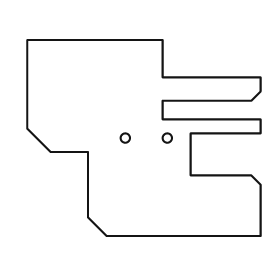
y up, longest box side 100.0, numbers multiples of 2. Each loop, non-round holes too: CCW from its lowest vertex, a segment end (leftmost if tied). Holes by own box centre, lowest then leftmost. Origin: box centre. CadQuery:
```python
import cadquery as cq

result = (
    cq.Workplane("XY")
    .moveTo(-16.0, -42.0)
    .lineTo(50.0, -42.0)
    .lineTo(50.0, -20.0)
    .lineTo(46.0, -16.0)
    .lineTo(20.0, -16.0)
    .lineTo(20.0, 2.0)
    .lineTo(50.0, 2.0)
    .lineTo(50.0, 8.0)
    .lineTo(8.0, 8.0)
    .lineTo(8.0, 16.0)
    .lineTo(46.0, 16.0)
    .lineTo(50.0, 20.0)
    .lineTo(50.0, 26.0)
    .lineTo(8.0, 26.0)
    .lineTo(8.0, 42.0)
    .lineTo(-50.0, 42.0)
    .lineTo(-50.0, 4.0)
    .lineTo(-40.0, -6.0)
    .lineTo(-24.0, -6.0)
    .lineTo(-24.0, -34.0)
    .close()
    .moveTo(-8.0, 0.0)
    .circle(2.0)
    .moveTo(10.0, 0.0)
    .circle(2.0)
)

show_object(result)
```